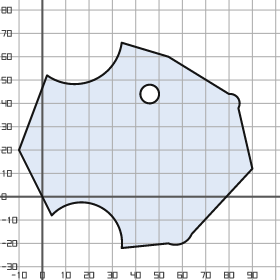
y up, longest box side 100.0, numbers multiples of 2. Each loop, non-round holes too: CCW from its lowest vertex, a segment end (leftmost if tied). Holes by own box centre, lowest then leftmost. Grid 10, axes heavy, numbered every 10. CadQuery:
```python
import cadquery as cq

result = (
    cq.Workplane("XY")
    .moveTo(34.0, -22.0)
    .lineTo(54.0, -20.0)
    .threePointArc((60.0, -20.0), (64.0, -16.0))
    .lineTo(90.0, 12.0)
    .lineTo(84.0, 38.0)
    .threePointArc((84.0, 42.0), (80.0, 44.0))
    .lineTo(54.0, 60.0)
    .lineTo(34.0, 66.0)
    .threePointArc((22.0, 50.0), (2.0, 52.0))
    .lineTo(-10.0, 20.0)
    .lineTo(4.0, -8.0)
    .threePointArc((24.0, -4.0), (34.0, -22.0))
    .close()
    .moveTo(46.0, 44.0)
    .circle(4.0)
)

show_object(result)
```